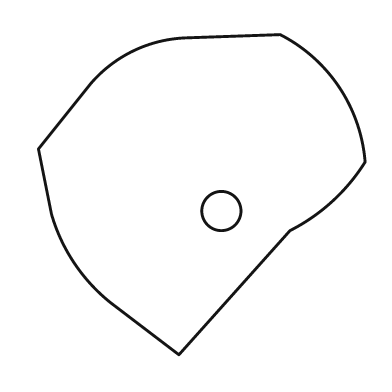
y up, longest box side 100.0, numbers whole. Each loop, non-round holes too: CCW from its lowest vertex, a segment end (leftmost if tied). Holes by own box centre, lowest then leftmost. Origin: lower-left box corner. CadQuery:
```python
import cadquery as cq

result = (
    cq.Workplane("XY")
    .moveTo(43.0, 0.0)
    .lineTo(77.0, 38.0)
    .threePointArc((90.0, 47.0), (100.0, 59.0))
    .threePointArc((92.0, 82.0), (74.0, 98.0))
    .lineTo(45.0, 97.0)
    .threePointArc((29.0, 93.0), (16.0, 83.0))
    .lineTo(0.0, 63.0)
    .lineTo(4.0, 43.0)
    .threePointArc((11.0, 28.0), (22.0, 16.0))
    .close()
    .moveTo(56.0, 44.0)
    .circle(6.0)
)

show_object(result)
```